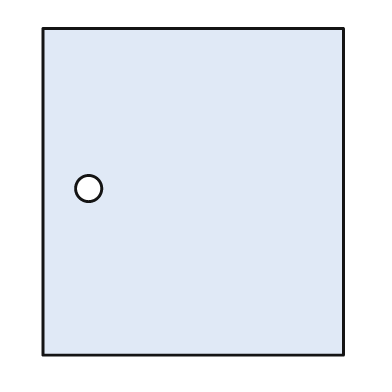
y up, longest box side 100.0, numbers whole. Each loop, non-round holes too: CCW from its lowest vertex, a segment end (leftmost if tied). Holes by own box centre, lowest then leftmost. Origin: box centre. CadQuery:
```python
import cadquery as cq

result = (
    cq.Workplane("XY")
    .moveTo(-46.0, -50.0)
    .lineTo(46.0, -50.0)
    .lineTo(46.0, 50.0)
    .lineTo(-46.0, 50.0)
    .close()
    .moveTo(-32.0, 1.0)
    .circle(4.0)
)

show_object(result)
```